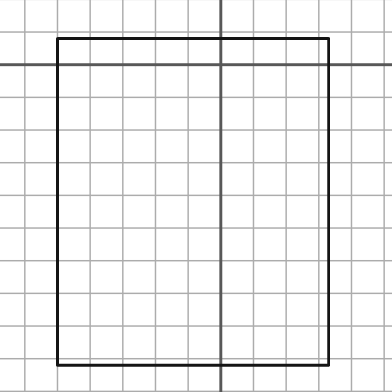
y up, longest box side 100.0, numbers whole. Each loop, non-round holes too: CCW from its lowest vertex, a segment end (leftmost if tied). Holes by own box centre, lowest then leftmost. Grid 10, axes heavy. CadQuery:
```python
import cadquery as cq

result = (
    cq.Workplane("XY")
    .moveTo(-50.0, -92.0)
    .lineTo(33.0, -92.0)
    .lineTo(33.0, 8.0)
    .lineTo(-50.0, 8.0)
    .close()
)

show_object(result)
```